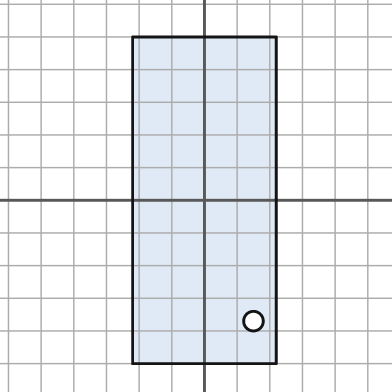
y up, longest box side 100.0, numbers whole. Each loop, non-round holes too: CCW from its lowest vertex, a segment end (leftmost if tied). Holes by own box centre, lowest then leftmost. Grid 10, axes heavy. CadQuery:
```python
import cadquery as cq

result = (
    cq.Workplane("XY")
    .moveTo(-22.0, -50.0)
    .lineTo(22.0, -50.0)
    .lineTo(22.0, 50.0)
    .lineTo(-22.0, 50.0)
    .close()
    .moveTo(15.0, -37.0)
    .circle(3.0)
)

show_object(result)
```